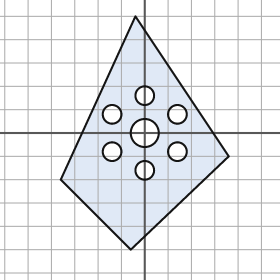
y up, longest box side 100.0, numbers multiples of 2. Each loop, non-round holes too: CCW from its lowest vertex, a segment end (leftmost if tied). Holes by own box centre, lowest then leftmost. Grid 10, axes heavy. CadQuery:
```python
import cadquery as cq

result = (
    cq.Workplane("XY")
    .moveTo(-6.0, -50.0)
    .lineTo(36.0, -10.0)
    .lineTo(-4.0, 50.0)
    .lineTo(-36.0, -20.0)
    .close()
    .moveTo(0.0, -16.0)
    .circle(4.0)
    .moveTo(-14.0, -8.0)
    .circle(4.0)
    .moveTo(14.0, -8.0)
    .circle(4.0)
    .moveTo(0.0, 0.0)
    .circle(6.0)
    .moveTo(-14.0, 8.0)
    .circle(4.0)
    .moveTo(14.0, 8.0)
    .circle(4.0)
    .moveTo(0.0, 16.0)
    .circle(4.0)
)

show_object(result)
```